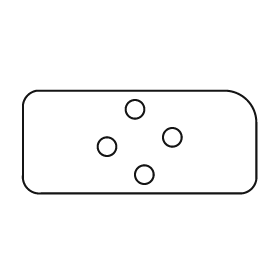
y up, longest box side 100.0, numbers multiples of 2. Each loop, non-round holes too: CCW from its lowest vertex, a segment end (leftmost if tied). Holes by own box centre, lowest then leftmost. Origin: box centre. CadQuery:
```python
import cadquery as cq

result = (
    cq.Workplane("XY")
    .moveTo(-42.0, -22.0)
    .lineTo(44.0, -22.0)
    .threePointArc((48.0, -20.0), (50.0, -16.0))
    .lineTo(50.0, 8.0)
    .threePointArc((46.0, 18.0), (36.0, 22.0))
    .lineTo(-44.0, 22.0)
    .threePointArc((-48.0, 20.0), (-50.0, 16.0))
    .lineTo(-50.0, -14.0)
    .threePointArc((-48.0, -20.0), (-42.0, -22.0))
    .close()
    .moveTo(2.0, -14.0)
    .circle(4.0)
    .moveTo(-14.0, -2.0)
    .circle(4.0)
    .moveTo(14.0, 2.0)
    .circle(4.0)
    .moveTo(-2.0, 14.0)
    .circle(4.0)
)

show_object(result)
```